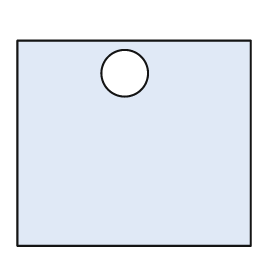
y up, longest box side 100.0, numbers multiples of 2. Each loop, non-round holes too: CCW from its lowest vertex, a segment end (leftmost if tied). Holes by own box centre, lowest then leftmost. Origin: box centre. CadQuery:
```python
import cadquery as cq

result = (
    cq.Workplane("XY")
    .moveTo(-50.0, -44.0)
    .lineTo(50.0, -44.0)
    .lineTo(50.0, 44.0)
    .lineTo(-50.0, 44.0)
    .close()
    .moveTo(-4.0, 30.0)
    .circle(10.0)
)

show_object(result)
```